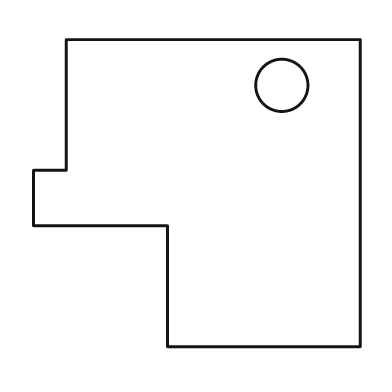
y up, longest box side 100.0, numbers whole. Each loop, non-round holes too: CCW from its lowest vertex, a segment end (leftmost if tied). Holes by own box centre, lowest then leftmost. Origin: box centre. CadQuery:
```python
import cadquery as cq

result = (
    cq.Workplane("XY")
    .moveTo(-9.0, -47.0)
    .lineTo(50.0, -47.0)
    .lineTo(50.0, 47.0)
    .lineTo(-40.0, 47.0)
    .lineTo(-40.0, 7.0)
    .lineTo(-50.0, 7.0)
    .lineTo(-50.0, -10.0)
    .lineTo(-9.0, -10.0)
    .close()
    .moveTo(26.0, 33.0)
    .circle(8.0)
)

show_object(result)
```